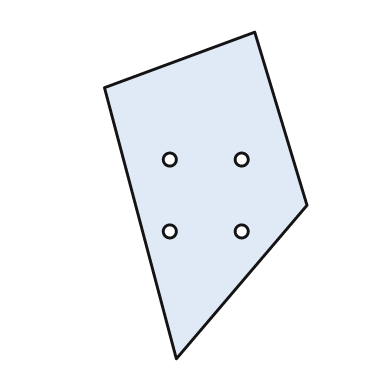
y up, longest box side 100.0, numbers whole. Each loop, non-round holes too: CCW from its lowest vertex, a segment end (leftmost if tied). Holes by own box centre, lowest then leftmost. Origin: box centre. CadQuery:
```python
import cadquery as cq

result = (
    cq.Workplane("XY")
    .moveTo(-9.0, -50.0)
    .lineTo(31.0, -3.0)
    .lineTo(15.0, 50.0)
    .lineTo(-31.0, 33.0)
    .close()
    .moveTo(-11.0, -11.0)
    .circle(2.0)
    .moveTo(11.0, -11.0)
    .circle(2.0)
    .moveTo(-11.0, 11.0)
    .circle(2.0)
    .moveTo(11.0, 11.0)
    .circle(2.0)
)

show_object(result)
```